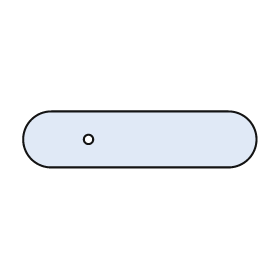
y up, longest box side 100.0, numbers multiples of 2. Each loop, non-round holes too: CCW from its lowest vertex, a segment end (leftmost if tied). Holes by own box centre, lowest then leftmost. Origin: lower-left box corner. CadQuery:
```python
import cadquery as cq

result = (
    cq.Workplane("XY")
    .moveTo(12.0, 0.0)
    .lineTo(88.0, 0.0)
    .threePointArc((100.0, 12.0), (88.0, 24.0))
    .lineTo(12.0, 24.0)
    .threePointArc((0.0, 12.0), (12.0, 0.0))
    .close()
    .moveTo(28.0, 12.0)
    .circle(2.0)
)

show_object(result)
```